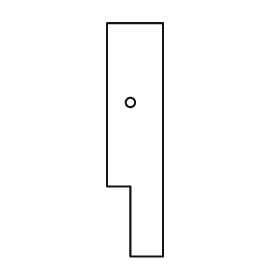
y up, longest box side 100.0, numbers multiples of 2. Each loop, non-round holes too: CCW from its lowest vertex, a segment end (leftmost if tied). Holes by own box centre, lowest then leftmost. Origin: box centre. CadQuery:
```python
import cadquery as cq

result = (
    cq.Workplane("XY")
    .moveTo(-2.0, -50.0)
    .lineTo(12.0, -50.0)
    .lineTo(12.0, 50.0)
    .lineTo(-12.0, 50.0)
    .lineTo(-12.0, -20.0)
    .lineTo(-2.0, -20.0)
    .close()
    .moveTo(-2.0, 16.0)
    .circle(2.0)
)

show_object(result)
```